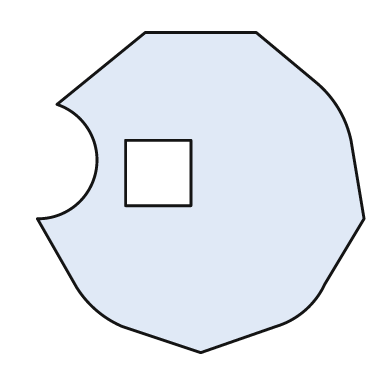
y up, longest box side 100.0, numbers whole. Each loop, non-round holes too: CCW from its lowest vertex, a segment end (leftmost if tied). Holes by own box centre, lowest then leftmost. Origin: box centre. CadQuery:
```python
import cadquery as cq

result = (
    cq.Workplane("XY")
    .moveTo(0.0, -49.0)
    .lineTo(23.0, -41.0)
    .threePointArc((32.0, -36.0), (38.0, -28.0))
    .lineTo(50.0, -8.0)
    .lineTo(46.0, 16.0)
    .threePointArc((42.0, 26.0), (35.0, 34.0))
    .lineTo(17.0, 49.0)
    .lineTo(-17.0, 49.0)
    .lineTo(-44.0, 27.0)
    .threePointArc((-32.0, 7.0), (-50.0, -8.0))
    .lineTo(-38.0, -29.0)
    .threePointArc((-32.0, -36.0), (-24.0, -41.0))
    .close()
    .moveTo(-23.0, -4.0)
    .lineTo(-3.0, -4.0)
    .lineTo(-3.0, 16.0)
    .lineTo(-23.0, 16.0)
    .close()
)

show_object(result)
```